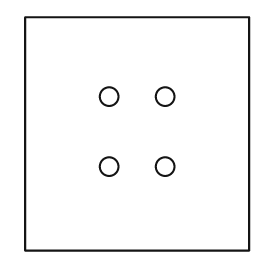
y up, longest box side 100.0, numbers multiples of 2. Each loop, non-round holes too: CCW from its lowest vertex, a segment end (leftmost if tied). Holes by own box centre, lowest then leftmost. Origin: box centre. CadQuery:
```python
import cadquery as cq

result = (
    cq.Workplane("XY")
    .moveTo(-48.0, -50.0)
    .lineTo(48.0, -50.0)
    .lineTo(48.0, 50.0)
    .lineTo(-48.0, 50.0)
    .close()
    .moveTo(-12.0, -14.0)
    .circle(4.0)
    .moveTo(12.0, -14.0)
    .circle(4.0)
    .moveTo(-12.0, 16.0)
    .circle(4.0)
    .moveTo(12.0, 16.0)
    .circle(4.0)
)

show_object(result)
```